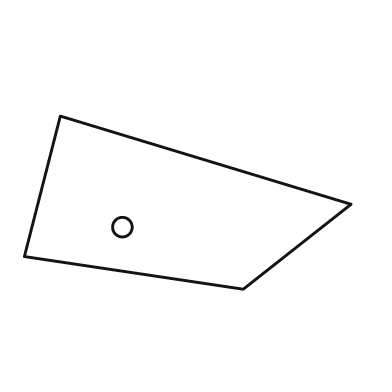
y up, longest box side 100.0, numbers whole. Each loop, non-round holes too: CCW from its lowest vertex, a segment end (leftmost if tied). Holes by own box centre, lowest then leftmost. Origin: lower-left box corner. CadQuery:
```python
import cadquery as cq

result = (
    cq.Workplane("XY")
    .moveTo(67.0, 0.0)
    .lineTo(100.0, 26.0)
    .lineTo(11.0, 53.0)
    .lineTo(0.0, 10.0)
    .close()
    .moveTo(30.0, 19.0)
    .circle(3.0)
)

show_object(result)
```